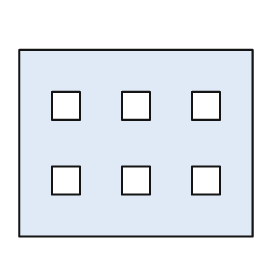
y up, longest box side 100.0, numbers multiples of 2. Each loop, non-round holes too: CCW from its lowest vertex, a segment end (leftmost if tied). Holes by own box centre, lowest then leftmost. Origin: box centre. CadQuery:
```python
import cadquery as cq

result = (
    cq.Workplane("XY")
    .moveTo(-50.0, -40.0)
    .lineTo(50.0, -40.0)
    .lineTo(50.0, 40.0)
    .lineTo(-50.0, 40.0)
    .close()
    .moveTo(-36.0, -22.0)
    .lineTo(-24.0, -22.0)
    .lineTo(-24.0, -10.0)
    .lineTo(-36.0, -10.0)
    .close()
    .moveTo(-6.0, -22.0)
    .lineTo(6.0, -22.0)
    .lineTo(6.0, -10.0)
    .lineTo(-6.0, -10.0)
    .close()
    .moveTo(24.0, -22.0)
    .lineTo(36.0, -22.0)
    .lineTo(36.0, -10.0)
    .lineTo(24.0, -10.0)
    .close()
    .moveTo(-36.0, 10.0)
    .lineTo(-24.0, 10.0)
    .lineTo(-24.0, 22.0)
    .lineTo(-36.0, 22.0)
    .close()
    .moveTo(-6.0, 10.0)
    .lineTo(6.0, 10.0)
    .lineTo(6.0, 22.0)
    .lineTo(-6.0, 22.0)
    .close()
    .moveTo(24.0, 10.0)
    .lineTo(36.0, 10.0)
    .lineTo(36.0, 22.0)
    .lineTo(24.0, 22.0)
    .close()
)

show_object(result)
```